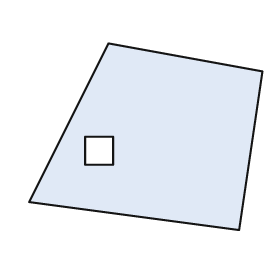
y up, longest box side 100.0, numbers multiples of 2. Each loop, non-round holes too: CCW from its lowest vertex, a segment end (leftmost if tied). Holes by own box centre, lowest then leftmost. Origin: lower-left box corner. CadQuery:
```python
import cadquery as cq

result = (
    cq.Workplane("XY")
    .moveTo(90.0, 0.0)
    .lineTo(100.0, 68.0)
    .lineTo(34.0, 80.0)
    .lineTo(0.0, 12.0)
    .close()
    .moveTo(24.0, 28.0)
    .lineTo(36.0, 28.0)
    .lineTo(36.0, 40.0)
    .lineTo(24.0, 40.0)
    .close()
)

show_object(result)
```